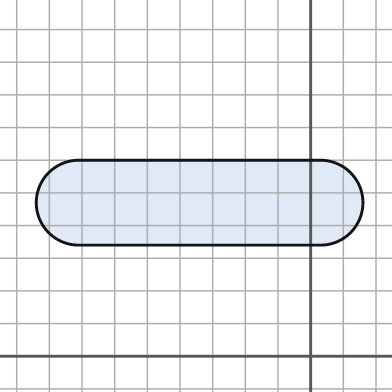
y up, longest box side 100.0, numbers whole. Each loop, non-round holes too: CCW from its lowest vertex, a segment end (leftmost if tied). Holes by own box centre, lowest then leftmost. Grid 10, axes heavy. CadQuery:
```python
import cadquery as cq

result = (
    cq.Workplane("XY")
    .moveTo(-71.0, 34.0)
    .lineTo(3.0, 34.0)
    .threePointArc((16.0, 47.0), (3.0, 60.0))
    .lineTo(-71.0, 60.0)
    .threePointArc((-84.0, 47.0), (-71.0, 34.0))
    .close()
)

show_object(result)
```